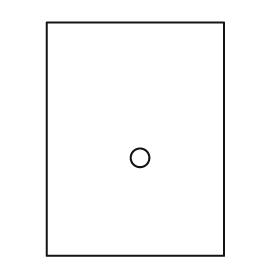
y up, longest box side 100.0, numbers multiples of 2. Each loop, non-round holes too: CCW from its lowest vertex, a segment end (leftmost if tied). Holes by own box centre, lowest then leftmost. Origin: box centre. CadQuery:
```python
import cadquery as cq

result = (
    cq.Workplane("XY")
    .moveTo(-38.0, -50.0)
    .lineTo(38.0, -50.0)
    .lineTo(38.0, 50.0)
    .lineTo(-38.0, 50.0)
    .close()
    .moveTo(2.0, -8.0)
    .circle(4.0)
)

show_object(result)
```